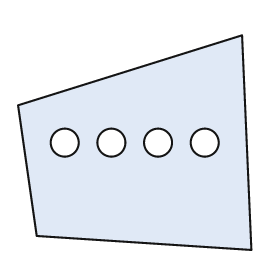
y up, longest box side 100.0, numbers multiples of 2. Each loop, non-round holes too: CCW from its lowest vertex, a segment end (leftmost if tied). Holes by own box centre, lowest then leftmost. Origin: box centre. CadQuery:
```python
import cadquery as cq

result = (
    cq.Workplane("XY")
    .moveTo(50.0, -46.0)
    .lineTo(46.0, 46.0)
    .lineTo(-50.0, 16.0)
    .lineTo(-42.0, -40.0)
    .close()
    .moveTo(-30.0, 0.0)
    .circle(6.0)
    .moveTo(-10.0, 0.0)
    .circle(6.0)
    .moveTo(10.0, 0.0)
    .circle(6.0)
    .moveTo(30.0, 0.0)
    .circle(6.0)
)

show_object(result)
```